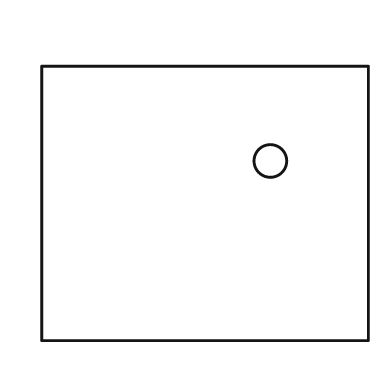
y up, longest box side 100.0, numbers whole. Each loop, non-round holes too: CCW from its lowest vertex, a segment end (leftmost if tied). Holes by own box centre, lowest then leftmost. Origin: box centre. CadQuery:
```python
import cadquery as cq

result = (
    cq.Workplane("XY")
    .moveTo(-50.0, -42.0)
    .lineTo(50.0, -42.0)
    .lineTo(50.0, 42.0)
    .lineTo(-50.0, 42.0)
    .close()
    .moveTo(20.0, 13.0)
    .circle(5.0)
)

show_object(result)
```